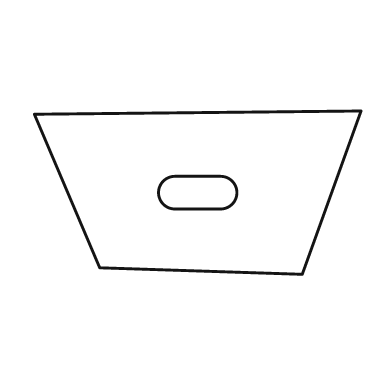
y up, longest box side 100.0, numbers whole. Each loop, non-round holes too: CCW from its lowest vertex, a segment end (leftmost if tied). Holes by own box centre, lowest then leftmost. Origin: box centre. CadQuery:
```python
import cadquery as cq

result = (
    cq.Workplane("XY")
    .moveTo(32.0, -25.0)
    .lineTo(50.0, 25.0)
    .lineTo(-50.0, 24.0)
    .lineTo(-30.0, -23.0)
    .close()
    .moveTo(-7.0, -5.0)
    .lineTo(7.0, -5.0)
    .threePointArc((12.0, 0.0), (7.0, 5.0))
    .lineTo(-7.0, 5.0)
    .threePointArc((-12.0, 0.0), (-7.0, -5.0))
    .close()
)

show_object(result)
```